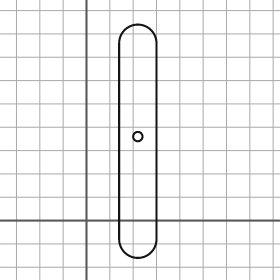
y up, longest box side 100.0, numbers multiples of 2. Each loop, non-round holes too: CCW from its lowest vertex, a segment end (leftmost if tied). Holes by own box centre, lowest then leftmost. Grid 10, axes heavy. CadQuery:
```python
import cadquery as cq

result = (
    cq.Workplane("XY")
    .moveTo(14.0, -8.0)
    .threePointArc((22.0, -16.0), (30.0, -8.0))
    .lineTo(30.0, 76.0)
    .threePointArc((22.0, 84.0), (14.0, 76.0))
    .close()
    .moveTo(22.0, 36.0)
    .circle(2.0)
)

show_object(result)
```